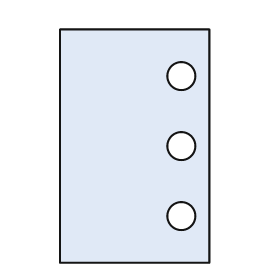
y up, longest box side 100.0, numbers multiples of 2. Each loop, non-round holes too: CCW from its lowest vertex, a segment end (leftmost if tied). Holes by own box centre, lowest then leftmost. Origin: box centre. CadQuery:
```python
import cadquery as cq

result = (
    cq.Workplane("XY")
    .moveTo(-32.0, -50.0)
    .lineTo(32.0, -50.0)
    .lineTo(32.0, 50.0)
    .lineTo(-32.0, 50.0)
    .close()
    .moveTo(20.0, -30.0)
    .circle(6.0)
    .moveTo(20.0, 0.0)
    .circle(6.0)
    .moveTo(20.0, 30.0)
    .circle(6.0)
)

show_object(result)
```